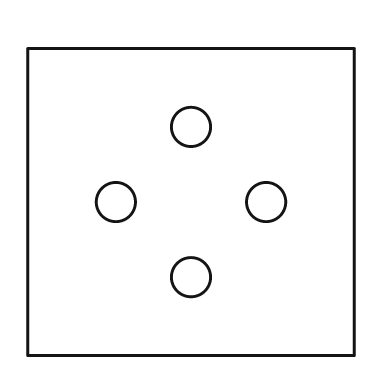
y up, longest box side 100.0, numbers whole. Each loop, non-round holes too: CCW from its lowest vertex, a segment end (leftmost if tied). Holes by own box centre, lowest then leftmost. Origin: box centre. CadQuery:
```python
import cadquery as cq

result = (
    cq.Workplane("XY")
    .moveTo(-50.0, -47.0)
    .lineTo(50.0, -47.0)
    .lineTo(50.0, 47.0)
    .lineTo(-50.0, 47.0)
    .close()
    .moveTo(0.0, -23.0)
    .circle(6.0)
    .moveTo(-23.0, 0.0)
    .circle(6.0)
    .moveTo(23.0, 0.0)
    .circle(6.0)
    .moveTo(0.0, 23.0)
    .circle(6.0)
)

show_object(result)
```